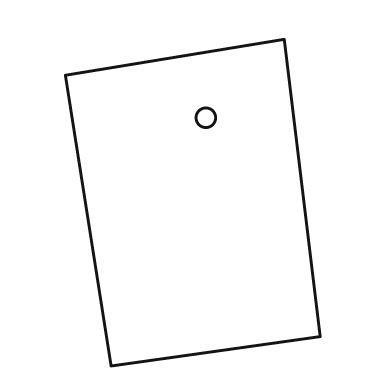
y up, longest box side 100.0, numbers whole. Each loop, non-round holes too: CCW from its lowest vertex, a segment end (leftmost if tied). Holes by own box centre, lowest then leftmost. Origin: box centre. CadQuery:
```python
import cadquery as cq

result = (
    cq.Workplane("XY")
    .moveTo(-25.0, -50.0)
    .lineTo(39.0, -41.0)
    .lineTo(28.0, 50.0)
    .lineTo(-39.0, 39.0)
    .close()
    .moveTo(4.0, 26.0)
    .circle(3.0)
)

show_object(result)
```